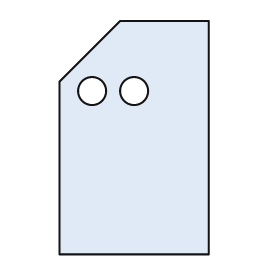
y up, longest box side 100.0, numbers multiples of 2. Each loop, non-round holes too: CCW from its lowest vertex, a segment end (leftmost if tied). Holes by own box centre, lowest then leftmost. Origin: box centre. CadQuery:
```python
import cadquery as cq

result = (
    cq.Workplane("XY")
    .moveTo(-32.0, -50.0)
    .lineTo(32.0, -50.0)
    .lineTo(32.0, 50.0)
    .lineTo(-6.0, 50.0)
    .lineTo(-32.0, 24.0)
    .close()
    .moveTo(-18.0, 20.0)
    .circle(6.0)
    .moveTo(0.0, 20.0)
    .circle(6.0)
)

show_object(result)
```